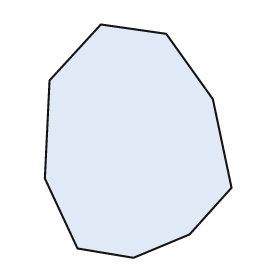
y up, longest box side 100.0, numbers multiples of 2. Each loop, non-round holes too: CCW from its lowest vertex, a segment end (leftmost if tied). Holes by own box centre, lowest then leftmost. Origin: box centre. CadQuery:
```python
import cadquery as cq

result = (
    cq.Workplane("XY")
    .moveTo(-2.0, -50.0)
    .lineTo(22.0, -40.0)
    .lineTo(40.0, -20.0)
    .lineTo(32.0, 18.0)
    .lineTo(12.0, 46.0)
    .lineTo(-16.0, 50.0)
    .lineTo(-38.0, 26.0)
    .lineTo(-40.0, -16.0)
    .lineTo(-26.0, -46.0)
    .close()
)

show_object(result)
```